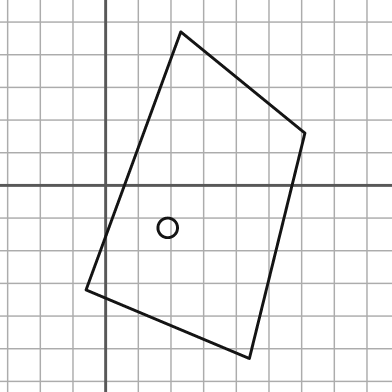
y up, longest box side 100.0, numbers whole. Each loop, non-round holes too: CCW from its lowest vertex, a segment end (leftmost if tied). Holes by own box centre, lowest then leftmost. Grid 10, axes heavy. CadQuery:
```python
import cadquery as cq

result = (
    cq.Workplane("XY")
    .moveTo(44.0, -53.0)
    .lineTo(61.0, 16.0)
    .lineTo(23.0, 47.0)
    .lineTo(-6.0, -32.0)
    .close()
    .moveTo(19.0, -13.0)
    .circle(3.0)
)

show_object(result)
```